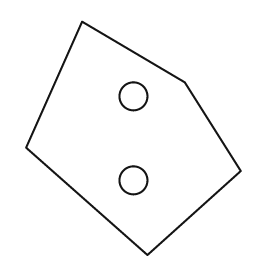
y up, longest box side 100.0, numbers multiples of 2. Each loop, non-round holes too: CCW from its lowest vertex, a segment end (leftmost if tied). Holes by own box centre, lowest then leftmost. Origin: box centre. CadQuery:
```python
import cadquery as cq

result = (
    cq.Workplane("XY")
    .moveTo(6.0, -50.0)
    .lineTo(46.0, -14.0)
    .lineTo(22.0, 24.0)
    .lineTo(-22.0, 50.0)
    .lineTo(-46.0, -4.0)
    .close()
    .moveTo(0.0, -18.0)
    .circle(6.0)
    .moveTo(0.0, 18.0)
    .circle(6.0)
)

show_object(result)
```